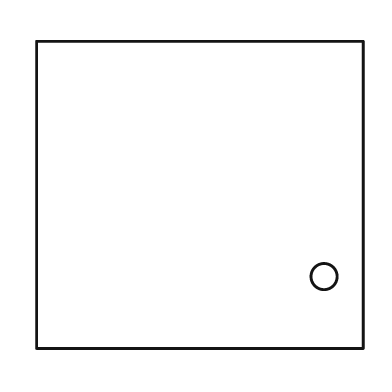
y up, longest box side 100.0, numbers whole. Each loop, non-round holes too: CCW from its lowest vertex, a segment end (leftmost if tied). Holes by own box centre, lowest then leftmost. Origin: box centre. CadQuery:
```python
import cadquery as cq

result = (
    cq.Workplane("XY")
    .moveTo(-50.0, -47.0)
    .lineTo(50.0, -47.0)
    .lineTo(50.0, 47.0)
    .lineTo(-50.0, 47.0)
    .close()
    .moveTo(38.0, -25.0)
    .circle(4.0)
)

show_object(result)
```